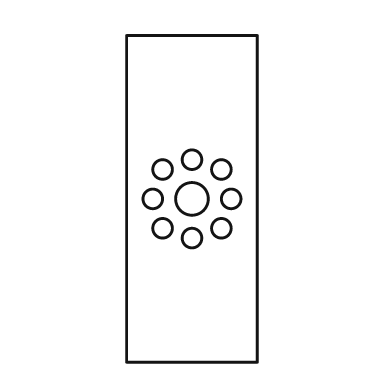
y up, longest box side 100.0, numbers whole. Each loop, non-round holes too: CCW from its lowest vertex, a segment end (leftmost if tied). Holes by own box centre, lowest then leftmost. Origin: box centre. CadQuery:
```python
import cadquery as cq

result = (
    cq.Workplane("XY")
    .moveTo(-20.0, -50.0)
    .lineTo(20.0, -50.0)
    .lineTo(20.0, 50.0)
    .lineTo(-20.0, 50.0)
    .close()
    .moveTo(0.0, -12.0)
    .circle(3.0)
    .moveTo(-9.0, -9.0)
    .circle(3.0)
    .moveTo(9.0, -9.0)
    .circle(3.0)
    .moveTo(-12.0, 0.0)
    .circle(3.0)
    .moveTo(0.0, 0.0)
    .circle(5.0)
    .moveTo(12.0, 0.0)
    .circle(3.0)
    .moveTo(-9.0, 9.0)
    .circle(3.0)
    .moveTo(9.0, 9.0)
    .circle(3.0)
    .moveTo(0.0, 12.0)
    .circle(3.0)
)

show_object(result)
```